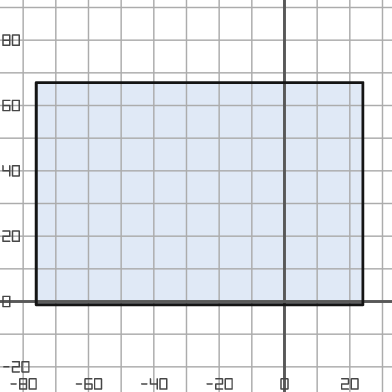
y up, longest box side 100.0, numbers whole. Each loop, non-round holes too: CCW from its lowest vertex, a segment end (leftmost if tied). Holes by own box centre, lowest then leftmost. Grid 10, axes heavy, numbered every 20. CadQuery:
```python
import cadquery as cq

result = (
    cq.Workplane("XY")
    .moveTo(-76.0, -1.0)
    .lineTo(24.0, -1.0)
    .lineTo(24.0, 67.0)
    .lineTo(-76.0, 67.0)
    .close()
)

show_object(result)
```